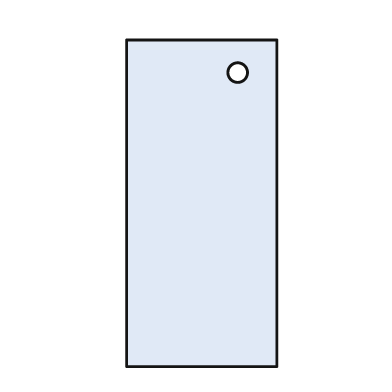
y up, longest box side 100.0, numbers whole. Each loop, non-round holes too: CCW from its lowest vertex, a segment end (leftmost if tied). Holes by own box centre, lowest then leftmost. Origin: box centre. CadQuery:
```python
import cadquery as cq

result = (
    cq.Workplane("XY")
    .moveTo(-23.0, -50.0)
    .lineTo(23.0, -50.0)
    .lineTo(23.0, 50.0)
    .lineTo(-23.0, 50.0)
    .close()
    .moveTo(11.0, 40.0)
    .circle(3.0)
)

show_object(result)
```